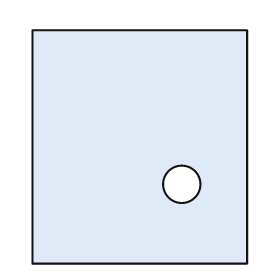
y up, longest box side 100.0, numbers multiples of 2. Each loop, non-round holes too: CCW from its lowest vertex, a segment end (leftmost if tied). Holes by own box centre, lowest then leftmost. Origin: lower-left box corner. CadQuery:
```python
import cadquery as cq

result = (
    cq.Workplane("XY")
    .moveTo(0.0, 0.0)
    .lineTo(92.0, 0.0)
    .lineTo(92.0, 100.0)
    .lineTo(0.0, 100.0)
    .close()
    .moveTo(64.0, 34.0)
    .circle(8.0)
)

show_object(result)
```